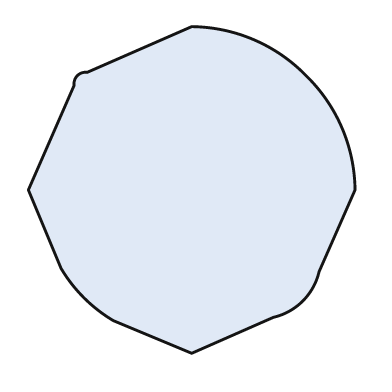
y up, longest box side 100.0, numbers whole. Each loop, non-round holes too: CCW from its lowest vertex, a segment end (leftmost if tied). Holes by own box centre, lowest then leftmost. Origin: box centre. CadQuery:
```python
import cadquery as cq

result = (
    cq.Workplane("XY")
    .moveTo(0.0, -50.0)
    .lineTo(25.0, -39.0)
    .threePointArc((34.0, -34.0), (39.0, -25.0))
    .lineTo(50.0, 0.0)
    .threePointArc((46.0, 19.0), (35.0, 35.0))
    .threePointArc((19.0, 46.0), (0.0, 50.0))
    .lineTo(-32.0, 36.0)
    .threePointArc((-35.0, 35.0), (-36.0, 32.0))
    .lineTo(-50.0, 0.0)
    .lineTo(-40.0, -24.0)
    .threePointArc((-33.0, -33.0), (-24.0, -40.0))
    .close()
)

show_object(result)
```